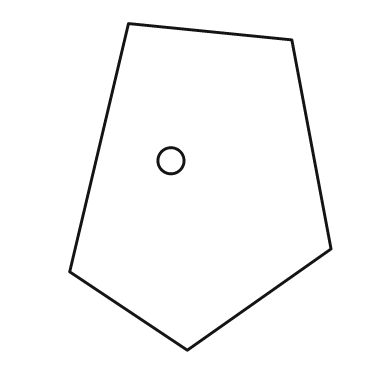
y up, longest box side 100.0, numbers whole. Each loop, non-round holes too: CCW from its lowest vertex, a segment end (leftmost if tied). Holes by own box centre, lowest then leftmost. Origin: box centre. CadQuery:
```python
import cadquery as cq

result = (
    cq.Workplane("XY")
    .moveTo(-4.0, -50.0)
    .lineTo(40.0, -19.0)
    .lineTo(28.0, 45.0)
    .lineTo(-22.0, 50.0)
    .lineTo(-40.0, -26.0)
    .close()
    .moveTo(-9.0, 8.0)
    .circle(4.0)
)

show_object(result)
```